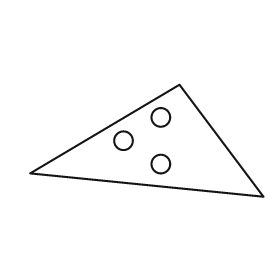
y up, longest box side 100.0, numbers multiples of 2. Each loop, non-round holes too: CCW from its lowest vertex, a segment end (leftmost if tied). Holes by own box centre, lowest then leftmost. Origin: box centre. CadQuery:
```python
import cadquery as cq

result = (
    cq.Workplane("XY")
    .moveTo(50.0, -24.0)
    .lineTo(14.0, 24.0)
    .lineTo(-50.0, -14.0)
    .close()
    .moveTo(6.0, -10.0)
    .circle(4.0)
    .moveTo(-10.0, 0.0)
    .circle(4.0)
    .moveTo(6.0, 10.0)
    .circle(4.0)
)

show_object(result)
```